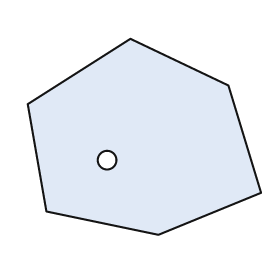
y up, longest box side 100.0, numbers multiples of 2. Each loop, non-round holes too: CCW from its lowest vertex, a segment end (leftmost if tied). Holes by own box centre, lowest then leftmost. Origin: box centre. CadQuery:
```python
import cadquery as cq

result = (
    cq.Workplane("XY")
    .moveTo(6.0, -42.0)
    .lineTo(50.0, -24.0)
    .lineTo(36.0, 22.0)
    .lineTo(-6.0, 42.0)
    .lineTo(-50.0, 14.0)
    .lineTo(-42.0, -32.0)
    .close()
    .moveTo(-16.0, -10.0)
    .circle(4.0)
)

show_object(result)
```